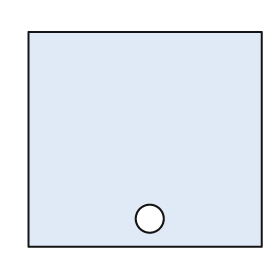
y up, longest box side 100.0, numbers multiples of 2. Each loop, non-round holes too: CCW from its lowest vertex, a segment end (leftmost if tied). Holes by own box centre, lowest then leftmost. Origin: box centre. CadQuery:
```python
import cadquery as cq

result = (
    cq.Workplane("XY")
    .moveTo(-50.0, -46.0)
    .lineTo(50.0, -46.0)
    .lineTo(50.0, 46.0)
    .lineTo(-50.0, 46.0)
    .close()
    .moveTo(2.0, -34.0)
    .circle(6.0)
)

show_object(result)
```